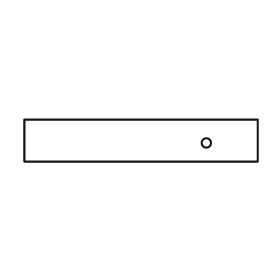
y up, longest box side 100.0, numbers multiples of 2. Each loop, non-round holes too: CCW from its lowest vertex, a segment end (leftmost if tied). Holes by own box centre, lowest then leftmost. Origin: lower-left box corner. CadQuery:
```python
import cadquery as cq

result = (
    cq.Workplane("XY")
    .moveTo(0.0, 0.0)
    .lineTo(100.0, 0.0)
    .lineTo(100.0, 18.0)
    .lineTo(0.0, 18.0)
    .close()
    .moveTo(78.0, 8.0)
    .circle(2.0)
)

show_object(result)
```